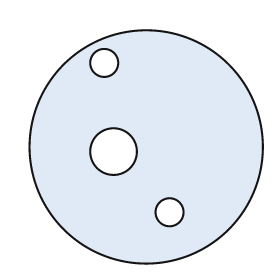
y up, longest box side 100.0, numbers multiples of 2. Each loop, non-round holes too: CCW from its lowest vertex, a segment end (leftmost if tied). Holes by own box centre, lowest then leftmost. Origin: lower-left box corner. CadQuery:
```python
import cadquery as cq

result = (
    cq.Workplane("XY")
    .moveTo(50.0, 50.0)
    .circle(50.0)
    .moveTo(60.0, 22.0)
    .circle(6.0)
    .moveTo(36.0, 48.0)
    .circle(10.0)
    .moveTo(32.0, 86.0)
    .circle(6.0)
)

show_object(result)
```